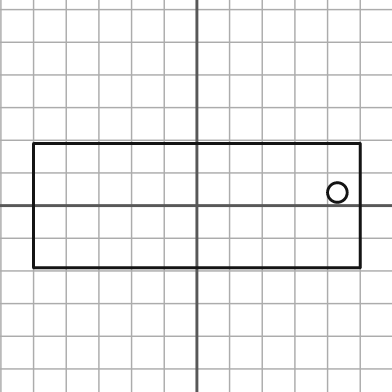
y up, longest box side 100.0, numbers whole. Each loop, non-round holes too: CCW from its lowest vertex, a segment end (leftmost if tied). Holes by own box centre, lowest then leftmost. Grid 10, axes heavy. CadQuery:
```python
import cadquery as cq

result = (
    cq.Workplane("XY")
    .moveTo(-50.0, -19.0)
    .lineTo(50.0, -19.0)
    .lineTo(50.0, 19.0)
    .lineTo(-50.0, 19.0)
    .close()
    .moveTo(43.0, 4.0)
    .circle(3.0)
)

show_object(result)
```